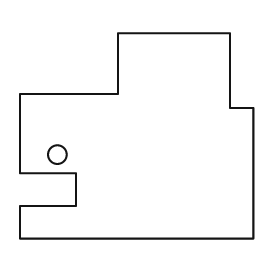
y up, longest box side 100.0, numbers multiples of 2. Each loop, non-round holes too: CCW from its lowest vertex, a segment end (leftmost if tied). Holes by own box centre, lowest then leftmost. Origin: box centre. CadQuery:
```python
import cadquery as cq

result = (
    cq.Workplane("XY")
    .moveTo(-50.0, -44.0)
    .lineTo(50.0, -44.0)
    .lineTo(50.0, 12.0)
    .lineTo(40.0, 12.0)
    .lineTo(40.0, 44.0)
    .lineTo(-8.0, 44.0)
    .lineTo(-8.0, 18.0)
    .lineTo(-50.0, 18.0)
    .lineTo(-50.0, -16.0)
    .lineTo(-26.0, -16.0)
    .lineTo(-26.0, -30.0)
    .lineTo(-50.0, -30.0)
    .close()
    .moveTo(-34.0, -8.0)
    .circle(4.0)
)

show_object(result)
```